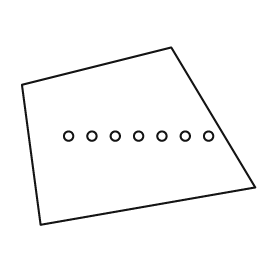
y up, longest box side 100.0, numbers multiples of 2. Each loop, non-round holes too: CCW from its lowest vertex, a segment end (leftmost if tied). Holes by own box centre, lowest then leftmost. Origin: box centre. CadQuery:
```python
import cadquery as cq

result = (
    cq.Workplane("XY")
    .moveTo(-42.0, -38.0)
    .lineTo(50.0, -22.0)
    .lineTo(14.0, 38.0)
    .lineTo(-50.0, 22.0)
    .close()
    .moveTo(-30.0, 0.0)
    .circle(2.0)
    .moveTo(-20.0, 0.0)
    .circle(2.0)
    .moveTo(-10.0, 0.0)
    .circle(2.0)
    .moveTo(0.0, 0.0)
    .circle(2.0)
    .moveTo(10.0, 0.0)
    .circle(2.0)
    .moveTo(20.0, 0.0)
    .circle(2.0)
    .moveTo(30.0, 0.0)
    .circle(2.0)
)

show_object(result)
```